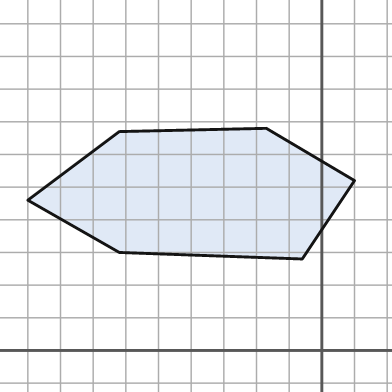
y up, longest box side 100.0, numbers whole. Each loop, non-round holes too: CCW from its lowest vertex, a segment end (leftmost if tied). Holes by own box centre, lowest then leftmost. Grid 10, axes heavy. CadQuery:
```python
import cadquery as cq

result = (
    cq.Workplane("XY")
    .moveTo(-6.0, 28.0)
    .lineTo(10.0, 52.0)
    .lineTo(-17.0, 68.0)
    .lineTo(-62.0, 67.0)
    .lineTo(-90.0, 46.0)
    .lineTo(-62.0, 30.0)
    .close()
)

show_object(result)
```